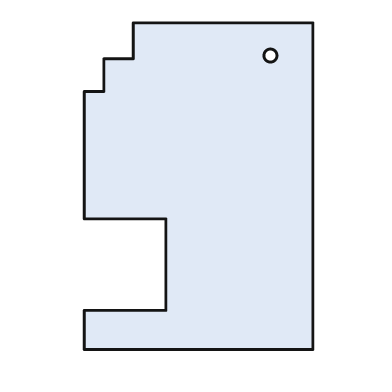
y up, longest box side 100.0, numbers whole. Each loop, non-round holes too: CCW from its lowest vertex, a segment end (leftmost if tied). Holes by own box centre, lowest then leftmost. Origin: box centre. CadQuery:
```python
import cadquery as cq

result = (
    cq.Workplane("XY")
    .moveTo(-35.0, -50.0)
    .lineTo(35.0, -50.0)
    .lineTo(35.0, 50.0)
    .lineTo(-20.0, 50.0)
    .lineTo(-20.0, 39.0)
    .lineTo(-29.0, 39.0)
    .lineTo(-29.0, 29.0)
    .lineTo(-35.0, 29.0)
    .lineTo(-35.0, -10.0)
    .lineTo(-10.0, -10.0)
    .lineTo(-10.0, -38.0)
    .lineTo(-35.0, -38.0)
    .close()
    .moveTo(22.0, 40.0)
    .circle(2.0)
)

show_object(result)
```